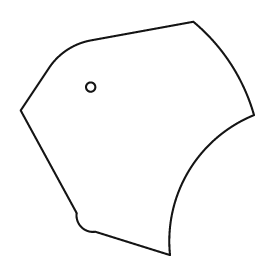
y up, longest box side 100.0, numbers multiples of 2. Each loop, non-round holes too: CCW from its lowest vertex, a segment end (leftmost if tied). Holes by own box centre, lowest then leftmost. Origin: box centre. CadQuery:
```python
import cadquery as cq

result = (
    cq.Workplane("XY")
    .moveTo(14.0, -50.0)
    .threePointArc((22.0, -14.0), (50.0, 10.0))
    .threePointArc((40.0, 32.0), (24.0, 50.0))
    .lineTo(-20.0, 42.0)
    .threePointArc((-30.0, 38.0), (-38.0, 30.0))
    .lineTo(-50.0, 12.0)
    .lineTo(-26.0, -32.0)
    .threePointArc((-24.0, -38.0), (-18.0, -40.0))
    .close()
    .moveTo(-20.0, 22.0)
    .circle(2.0)
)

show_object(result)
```